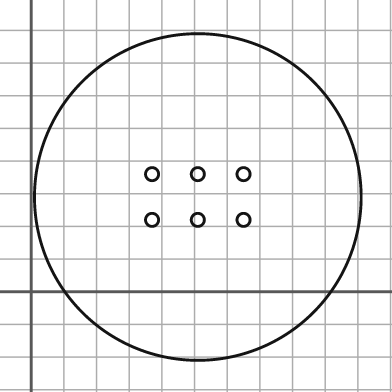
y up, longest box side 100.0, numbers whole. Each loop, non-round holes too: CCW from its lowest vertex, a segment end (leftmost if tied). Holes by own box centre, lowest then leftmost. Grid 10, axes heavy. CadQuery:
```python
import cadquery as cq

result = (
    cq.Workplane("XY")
    .moveTo(51.0, 29.0)
    .circle(50.0)
    .moveTo(37.0, 22.0)
    .circle(2.0)
    .moveTo(51.0, 22.0)
    .circle(2.0)
    .moveTo(65.0, 22.0)
    .circle(2.0)
    .moveTo(37.0, 36.0)
    .circle(2.0)
    .moveTo(51.0, 36.0)
    .circle(2.0)
    .moveTo(65.0, 36.0)
    .circle(2.0)
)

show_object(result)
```